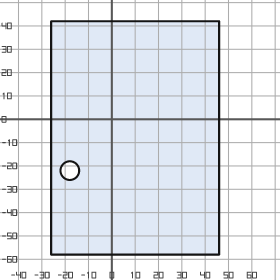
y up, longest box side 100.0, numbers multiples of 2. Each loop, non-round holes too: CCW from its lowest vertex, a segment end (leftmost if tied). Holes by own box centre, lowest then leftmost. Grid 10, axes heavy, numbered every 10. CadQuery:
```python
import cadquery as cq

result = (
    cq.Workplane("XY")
    .moveTo(-26.0, -58.0)
    .lineTo(46.0, -58.0)
    .lineTo(46.0, 42.0)
    .lineTo(-26.0, 42.0)
    .close()
    .moveTo(-18.0, -22.0)
    .circle(4.0)
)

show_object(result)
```